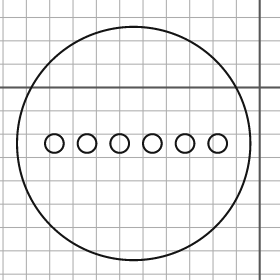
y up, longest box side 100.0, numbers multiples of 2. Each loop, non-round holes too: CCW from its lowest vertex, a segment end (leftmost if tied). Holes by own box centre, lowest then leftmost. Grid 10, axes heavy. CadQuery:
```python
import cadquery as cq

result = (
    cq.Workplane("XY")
    .moveTo(-54.0, -24.0)
    .circle(50.0)
    .moveTo(-88.0, -24.0)
    .circle(4.0)
    .moveTo(-74.0, -24.0)
    .circle(4.0)
    .moveTo(-60.0, -24.0)
    .circle(4.0)
    .moveTo(-46.0, -24.0)
    .circle(4.0)
    .moveTo(-32.0, -24.0)
    .circle(4.0)
    .moveTo(-18.0, -24.0)
    .circle(4.0)
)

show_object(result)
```